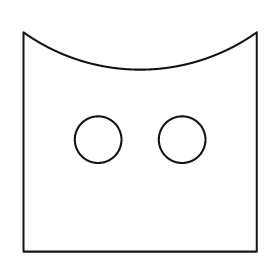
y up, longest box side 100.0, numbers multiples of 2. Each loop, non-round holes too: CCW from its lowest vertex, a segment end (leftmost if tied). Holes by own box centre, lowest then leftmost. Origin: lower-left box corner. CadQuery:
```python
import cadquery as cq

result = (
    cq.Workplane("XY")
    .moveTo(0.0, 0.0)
    .lineTo(100.0, 0.0)
    .lineTo(100.0, 94.0)
    .threePointArc((50.0, 78.0), (0.0, 94.0))
    .close()
    .moveTo(32.0, 48.0)
    .circle(10.0)
    .moveTo(68.0, 48.0)
    .circle(10.0)
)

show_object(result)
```